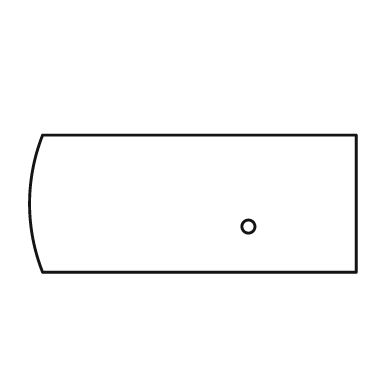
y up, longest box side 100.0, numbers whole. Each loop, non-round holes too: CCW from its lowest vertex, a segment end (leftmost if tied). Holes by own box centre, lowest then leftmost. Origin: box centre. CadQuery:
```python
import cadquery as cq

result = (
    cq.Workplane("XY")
    .moveTo(-46.0, -21.0)
    .lineTo(50.0, -21.0)
    .lineTo(50.0, 21.0)
    .lineTo(-46.0, 21.0)
    .threePointArc((-50.0, 0.0), (-46.0, -21.0))
    .close()
    .moveTo(17.0, -7.0)
    .circle(2.0)
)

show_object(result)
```